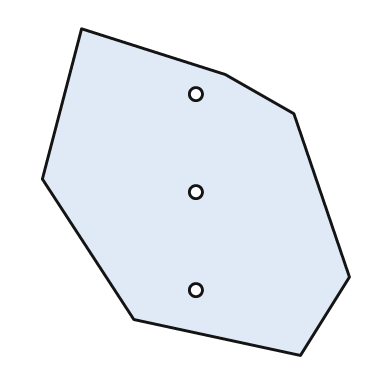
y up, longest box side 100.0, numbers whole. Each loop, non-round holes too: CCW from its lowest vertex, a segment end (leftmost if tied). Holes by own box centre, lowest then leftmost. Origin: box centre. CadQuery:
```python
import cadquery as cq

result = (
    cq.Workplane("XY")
    .moveTo(32.0, -50.0)
    .lineTo(47.0, -26.0)
    .lineTo(30.0, 24.0)
    .lineTo(9.0, 36.0)
    .lineTo(-35.0, 50.0)
    .lineTo(-47.0, 4.0)
    .lineTo(-19.0, -39.0)
    .close()
    .moveTo(0.0, -30.0)
    .circle(2.0)
    .moveTo(0.0, 0.0)
    .circle(2.0)
    .moveTo(0.0, 30.0)
    .circle(2.0)
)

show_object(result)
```